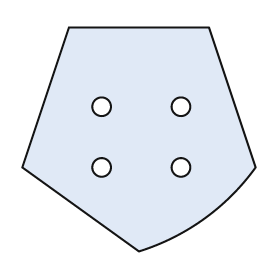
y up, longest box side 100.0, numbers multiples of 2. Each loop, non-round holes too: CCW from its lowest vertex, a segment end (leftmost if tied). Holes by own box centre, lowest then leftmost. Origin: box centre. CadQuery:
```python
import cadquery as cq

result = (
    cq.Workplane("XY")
    .moveTo(0.0, -48.0)
    .threePointArc((28.0, -34.0), (50.0, -12.0))
    .lineTo(30.0, 48.0)
    .lineTo(-30.0, 48.0)
    .lineTo(-50.0, -12.0)
    .close()
    .moveTo(-16.0, -12.0)
    .circle(4.0)
    .moveTo(18.0, -12.0)
    .circle(4.0)
    .moveTo(-16.0, 14.0)
    .circle(4.0)
    .moveTo(18.0, 14.0)
    .circle(4.0)
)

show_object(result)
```